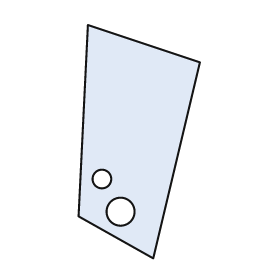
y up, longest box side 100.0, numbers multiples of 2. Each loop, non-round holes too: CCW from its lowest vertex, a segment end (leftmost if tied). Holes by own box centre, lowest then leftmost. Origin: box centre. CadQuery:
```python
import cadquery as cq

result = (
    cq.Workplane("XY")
    .moveTo(6.0, -50.0)
    .lineTo(26.0, 34.0)
    .lineTo(-22.0, 50.0)
    .lineTo(-26.0, -32.0)
    .close()
    .moveTo(-8.0, -30.0)
    .circle(6.0)
    .moveTo(-16.0, -16.0)
    .circle(4.0)
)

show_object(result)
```